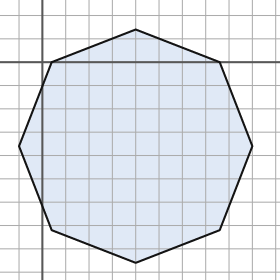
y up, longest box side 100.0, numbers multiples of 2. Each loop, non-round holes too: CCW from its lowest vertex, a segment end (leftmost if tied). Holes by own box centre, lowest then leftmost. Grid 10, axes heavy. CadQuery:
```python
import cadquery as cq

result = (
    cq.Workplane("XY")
    .moveTo(40.0, -86.0)
    .lineTo(76.0, -72.0)
    .lineTo(90.0, -36.0)
    .lineTo(76.0, 0.0)
    .lineTo(40.0, 14.0)
    .lineTo(4.0, 0.0)
    .lineTo(-10.0, -36.0)
    .lineTo(4.0, -72.0)
    .close()
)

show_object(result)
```